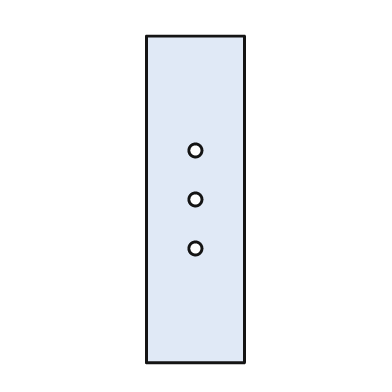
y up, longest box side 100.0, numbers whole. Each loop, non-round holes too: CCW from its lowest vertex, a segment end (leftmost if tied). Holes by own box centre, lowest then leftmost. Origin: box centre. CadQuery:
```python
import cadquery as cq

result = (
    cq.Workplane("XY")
    .moveTo(-15.0, -50.0)
    .lineTo(15.0, -50.0)
    .lineTo(15.0, 50.0)
    .lineTo(-15.0, 50.0)
    .close()
    .moveTo(0.0, -15.0)
    .circle(2.0)
    .moveTo(0.0, 0.0)
    .circle(2.0)
    .moveTo(0.0, 15.0)
    .circle(2.0)
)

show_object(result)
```